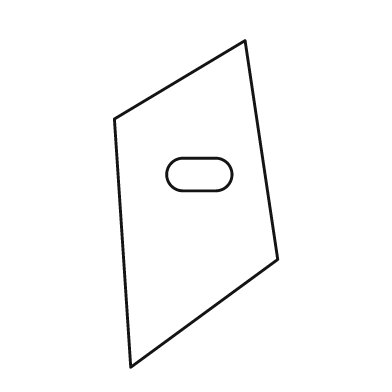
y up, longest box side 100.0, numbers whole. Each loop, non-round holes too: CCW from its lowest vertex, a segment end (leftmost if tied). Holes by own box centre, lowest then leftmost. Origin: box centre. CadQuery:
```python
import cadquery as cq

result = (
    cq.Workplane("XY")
    .moveTo(-20.0, -50.0)
    .lineTo(25.0, -17.0)
    .lineTo(15.0, 50.0)
    .lineTo(-25.0, 26.0)
    .close()
    .moveTo(-4.0, 4.0)
    .lineTo(6.0, 4.0)
    .threePointArc((11.0, 9.0), (6.0, 14.0))
    .lineTo(-4.0, 14.0)
    .threePointArc((-9.0, 9.0), (-4.0, 4.0))
    .close()
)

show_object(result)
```